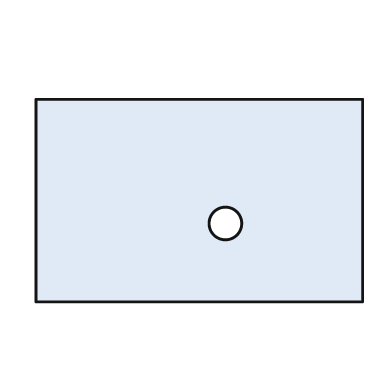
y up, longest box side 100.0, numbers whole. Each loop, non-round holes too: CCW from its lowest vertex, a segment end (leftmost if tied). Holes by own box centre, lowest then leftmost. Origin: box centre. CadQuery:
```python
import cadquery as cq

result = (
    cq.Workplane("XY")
    .moveTo(-50.0, -31.0)
    .lineTo(50.0, -31.0)
    .lineTo(50.0, 31.0)
    .lineTo(-50.0, 31.0)
    .close()
    .moveTo(8.0, -7.0)
    .circle(5.0)
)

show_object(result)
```